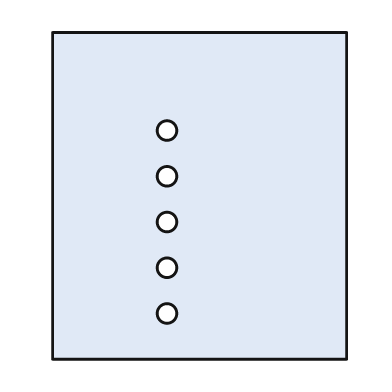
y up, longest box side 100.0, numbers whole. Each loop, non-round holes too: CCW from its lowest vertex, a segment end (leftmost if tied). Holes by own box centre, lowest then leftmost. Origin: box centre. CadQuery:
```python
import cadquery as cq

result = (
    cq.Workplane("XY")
    .moveTo(-45.0, -50.0)
    .lineTo(45.0, -50.0)
    .lineTo(45.0, 50.0)
    .lineTo(-45.0, 50.0)
    .close()
    .moveTo(-10.0, -36.0)
    .circle(3.0)
    .moveTo(-10.0, -22.0)
    .circle(3.0)
    .moveTo(-10.0, -8.0)
    .circle(3.0)
    .moveTo(-10.0, 6.0)
    .circle(3.0)
    .moveTo(-10.0, 20.0)
    .circle(3.0)
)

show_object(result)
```